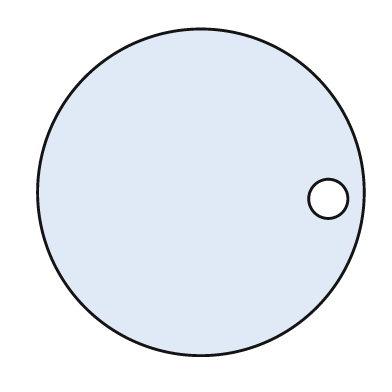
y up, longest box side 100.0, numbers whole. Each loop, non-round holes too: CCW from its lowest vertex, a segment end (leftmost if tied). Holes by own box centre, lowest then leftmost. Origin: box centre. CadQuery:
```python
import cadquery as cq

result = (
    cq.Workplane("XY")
    .moveTo(0.0, 0.0)
    .circle(50.0)
    .moveTo(39.0, -2.0)
    .circle(6.0)
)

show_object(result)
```